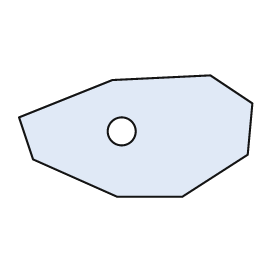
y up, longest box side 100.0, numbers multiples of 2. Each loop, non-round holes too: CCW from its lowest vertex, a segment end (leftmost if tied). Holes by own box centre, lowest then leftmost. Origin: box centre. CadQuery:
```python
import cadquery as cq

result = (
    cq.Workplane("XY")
    .moveTo(-8.0, -26.0)
    .lineTo(20.0, -26.0)
    .lineTo(48.0, -8.0)
    .lineTo(50.0, 14.0)
    .lineTo(32.0, 26.0)
    .lineTo(-10.0, 24.0)
    .lineTo(-50.0, 8.0)
    .lineTo(-44.0, -10.0)
    .close()
    .moveTo(-6.0, 2.0)
    .circle(6.0)
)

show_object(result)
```